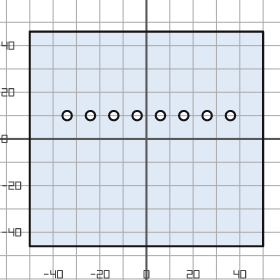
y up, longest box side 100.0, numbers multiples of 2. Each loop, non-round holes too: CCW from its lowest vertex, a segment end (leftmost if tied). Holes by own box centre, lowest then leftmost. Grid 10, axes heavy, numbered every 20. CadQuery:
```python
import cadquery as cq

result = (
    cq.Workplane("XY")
    .moveTo(-50.0, -46.0)
    .lineTo(50.0, -46.0)
    .lineTo(50.0, 46.0)
    .lineTo(-50.0, 46.0)
    .close()
    .moveTo(-34.0, 10.0)
    .circle(2.0)
    .moveTo(-24.0, 10.0)
    .circle(2.0)
    .moveTo(-14.0, 10.0)
    .circle(2.0)
    .moveTo(-4.0, 10.0)
    .circle(2.0)
    .moveTo(6.0, 10.0)
    .circle(2.0)
    .moveTo(16.0, 10.0)
    .circle(2.0)
    .moveTo(26.0, 10.0)
    .circle(2.0)
    .moveTo(36.0, 10.0)
    .circle(2.0)
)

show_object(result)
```